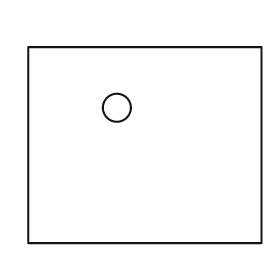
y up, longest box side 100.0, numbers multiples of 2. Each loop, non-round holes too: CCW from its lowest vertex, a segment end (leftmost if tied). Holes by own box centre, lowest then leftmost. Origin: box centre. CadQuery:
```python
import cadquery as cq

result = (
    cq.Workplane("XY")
    .moveTo(-50.0, -42.0)
    .lineTo(50.0, -42.0)
    .lineTo(50.0, 42.0)
    .lineTo(-50.0, 42.0)
    .close()
    .moveTo(-12.0, 16.0)
    .circle(6.0)
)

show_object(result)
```